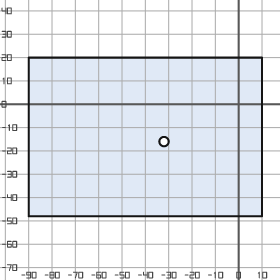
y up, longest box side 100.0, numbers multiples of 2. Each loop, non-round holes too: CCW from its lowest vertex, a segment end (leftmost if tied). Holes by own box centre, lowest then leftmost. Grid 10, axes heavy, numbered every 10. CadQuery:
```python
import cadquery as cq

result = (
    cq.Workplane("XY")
    .moveTo(-90.0, -48.0)
    .lineTo(10.0, -48.0)
    .lineTo(10.0, 20.0)
    .lineTo(-90.0, 20.0)
    .close()
    .moveTo(-32.0, -16.0)
    .circle(2.0)
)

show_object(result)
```